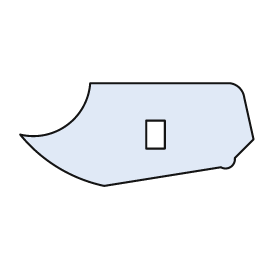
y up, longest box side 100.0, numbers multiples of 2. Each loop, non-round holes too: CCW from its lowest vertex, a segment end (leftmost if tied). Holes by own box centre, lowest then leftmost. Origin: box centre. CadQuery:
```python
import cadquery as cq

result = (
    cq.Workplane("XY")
    .moveTo(-14.0, -22.0)
    .lineTo(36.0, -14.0)
    .threePointArc((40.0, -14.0), (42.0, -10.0))
    .lineTo(50.0, -2.0)
    .lineTo(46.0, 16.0)
    .threePointArc((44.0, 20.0), (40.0, 22.0))
    .lineTo(-20.0, 22.0)
    .threePointArc((-30.0, 4.0), (-50.0, 0.0))
    .threePointArc((-34.0, -14.0), (-14.0, -22.0))
    .close()
    .moveTo(4.0, -6.0)
    .lineTo(12.0, -6.0)
    .lineTo(12.0, 6.0)
    .lineTo(4.0, 6.0)
    .close()
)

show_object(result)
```